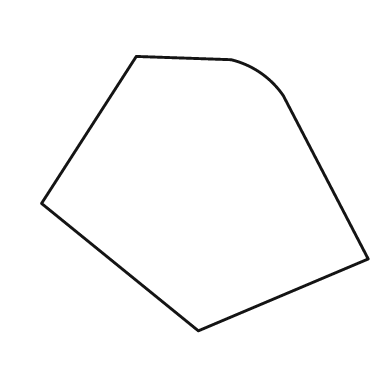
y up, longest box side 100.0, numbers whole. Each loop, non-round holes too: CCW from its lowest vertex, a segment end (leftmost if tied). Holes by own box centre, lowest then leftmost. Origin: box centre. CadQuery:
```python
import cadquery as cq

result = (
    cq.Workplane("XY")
    .moveTo(-2.0, -42.0)
    .lineTo(50.0, -20.0)
    .lineTo(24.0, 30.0)
    .threePointArc((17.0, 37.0), (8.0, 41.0))
    .lineTo(-21.0, 42.0)
    .lineTo(-50.0, -3.0)
    .close()
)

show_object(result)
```